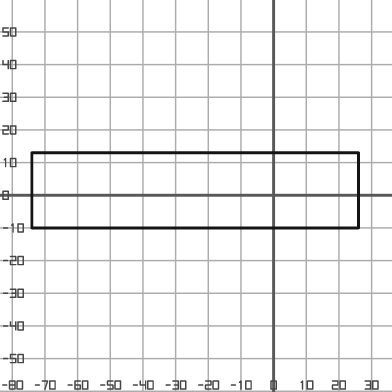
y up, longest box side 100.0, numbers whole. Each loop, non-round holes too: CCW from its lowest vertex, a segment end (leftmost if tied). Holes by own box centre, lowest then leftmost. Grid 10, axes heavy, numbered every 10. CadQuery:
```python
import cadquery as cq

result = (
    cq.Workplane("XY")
    .moveTo(-74.0, -10.0)
    .lineTo(26.0, -10.0)
    .lineTo(26.0, 13.0)
    .lineTo(-74.0, 13.0)
    .close()
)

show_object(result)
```